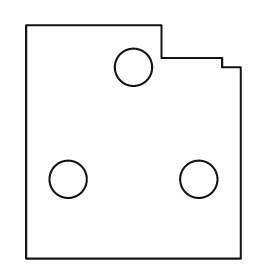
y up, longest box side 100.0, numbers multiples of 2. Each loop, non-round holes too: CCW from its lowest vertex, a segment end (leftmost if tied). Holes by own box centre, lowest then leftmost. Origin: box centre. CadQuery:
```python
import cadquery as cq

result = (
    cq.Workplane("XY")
    .moveTo(-46.0, -50.0)
    .lineTo(46.0, -50.0)
    .lineTo(46.0, 32.0)
    .lineTo(38.0, 32.0)
    .lineTo(38.0, 36.0)
    .lineTo(12.0, 36.0)
    .lineTo(12.0, 50.0)
    .lineTo(-46.0, 50.0)
    .close()
    .moveTo(-28.0, -16.0)
    .circle(8.0)
    .moveTo(28.0, -16.0)
    .circle(8.0)
    .moveTo(0.0, 32.0)
    .circle(8.0)
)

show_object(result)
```